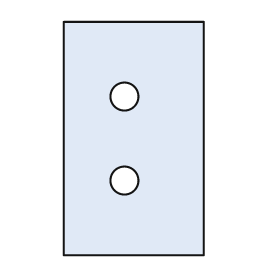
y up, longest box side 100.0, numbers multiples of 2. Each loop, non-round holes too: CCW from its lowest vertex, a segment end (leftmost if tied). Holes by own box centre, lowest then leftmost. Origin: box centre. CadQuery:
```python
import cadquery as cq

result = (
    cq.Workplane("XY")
    .moveTo(-30.0, -50.0)
    .lineTo(30.0, -50.0)
    .lineTo(30.0, 50.0)
    .lineTo(-30.0, 50.0)
    .close()
    .moveTo(-4.0, -18.0)
    .circle(6.0)
    .moveTo(-4.0, 18.0)
    .circle(6.0)
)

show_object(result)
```